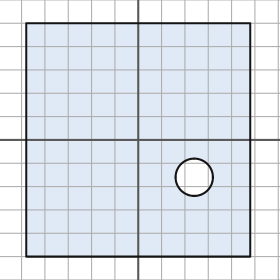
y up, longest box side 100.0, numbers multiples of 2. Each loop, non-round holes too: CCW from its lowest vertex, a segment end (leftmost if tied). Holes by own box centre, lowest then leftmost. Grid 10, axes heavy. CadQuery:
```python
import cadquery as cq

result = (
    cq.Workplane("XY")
    .moveTo(-48.0, -50.0)
    .lineTo(48.0, -50.0)
    .lineTo(48.0, 50.0)
    .lineTo(-48.0, 50.0)
    .close()
    .moveTo(24.0, -16.0)
    .circle(8.0)
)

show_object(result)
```